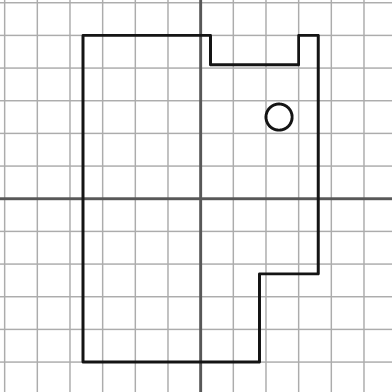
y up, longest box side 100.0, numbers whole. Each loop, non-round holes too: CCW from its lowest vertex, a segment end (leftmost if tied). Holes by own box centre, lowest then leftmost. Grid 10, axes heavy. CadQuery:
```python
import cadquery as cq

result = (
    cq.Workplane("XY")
    .moveTo(-36.0, -50.0)
    .lineTo(18.0, -50.0)
    .lineTo(18.0, -23.0)
    .lineTo(36.0, -23.0)
    .lineTo(36.0, 50.0)
    .lineTo(30.0, 50.0)
    .lineTo(30.0, 41.0)
    .lineTo(3.0, 41.0)
    .lineTo(3.0, 50.0)
    .lineTo(-36.0, 50.0)
    .close()
    .moveTo(24.0, 25.0)
    .circle(4.0)
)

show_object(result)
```